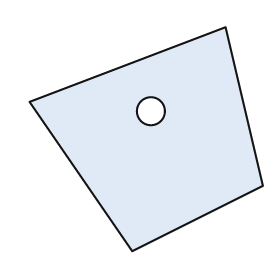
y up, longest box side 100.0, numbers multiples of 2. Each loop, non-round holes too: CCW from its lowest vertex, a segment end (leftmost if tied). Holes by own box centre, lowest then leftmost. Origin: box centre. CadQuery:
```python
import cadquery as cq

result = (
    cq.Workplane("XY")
    .moveTo(-6.0, -48.0)
    .lineTo(50.0, -20.0)
    .lineTo(34.0, 48.0)
    .lineTo(-50.0, 16.0)
    .close()
    .moveTo(2.0, 12.0)
    .circle(6.0)
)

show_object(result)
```